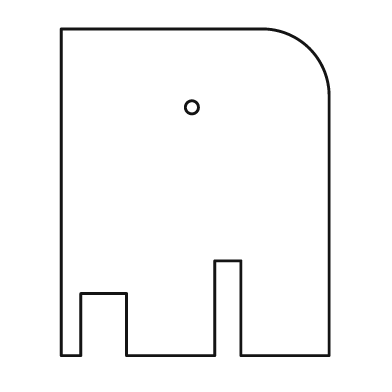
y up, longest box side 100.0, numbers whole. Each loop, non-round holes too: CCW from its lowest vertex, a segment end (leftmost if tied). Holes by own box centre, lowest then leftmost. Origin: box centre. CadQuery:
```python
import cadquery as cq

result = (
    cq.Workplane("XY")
    .moveTo(-41.0, -50.0)
    .lineTo(-35.0, -50.0)
    .lineTo(-35.0, -31.0)
    .lineTo(-21.0, -31.0)
    .lineTo(-21.0, -50.0)
    .lineTo(6.0, -50.0)
    .lineTo(6.0, -21.0)
    .lineTo(14.0, -21.0)
    .lineTo(14.0, -50.0)
    .lineTo(41.0, -50.0)
    .lineTo(41.0, 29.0)
    .threePointArc((35.0, 44.0), (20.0, 50.0))
    .lineTo(-41.0, 50.0)
    .close()
    .moveTo(-1.0, 26.0)
    .circle(2.0)
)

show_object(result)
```